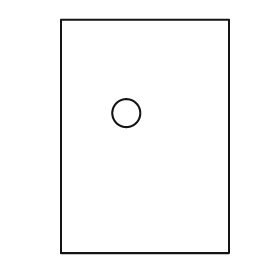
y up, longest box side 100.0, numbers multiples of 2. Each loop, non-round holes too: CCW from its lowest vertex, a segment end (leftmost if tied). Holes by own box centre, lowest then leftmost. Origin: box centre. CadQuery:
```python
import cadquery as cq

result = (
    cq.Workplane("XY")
    .moveTo(-36.0, -50.0)
    .lineTo(36.0, -50.0)
    .lineTo(36.0, 50.0)
    .lineTo(-36.0, 50.0)
    .close()
    .moveTo(-8.0, 10.0)
    .circle(6.0)
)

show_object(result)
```